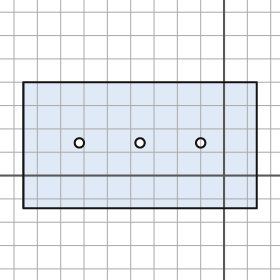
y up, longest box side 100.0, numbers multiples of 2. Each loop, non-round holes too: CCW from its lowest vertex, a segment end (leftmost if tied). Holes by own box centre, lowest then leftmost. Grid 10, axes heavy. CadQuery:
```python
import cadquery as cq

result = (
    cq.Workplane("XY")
    .moveTo(-86.0, -14.0)
    .lineTo(14.0, -14.0)
    .lineTo(14.0, 40.0)
    .lineTo(-86.0, 40.0)
    .close()
    .moveTo(-62.0, 14.0)
    .circle(2.0)
    .moveTo(-36.0, 14.0)
    .circle(2.0)
    .moveTo(-10.0, 14.0)
    .circle(2.0)
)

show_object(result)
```